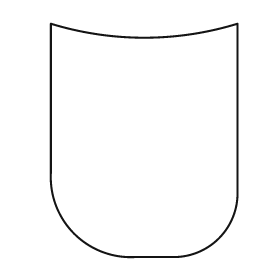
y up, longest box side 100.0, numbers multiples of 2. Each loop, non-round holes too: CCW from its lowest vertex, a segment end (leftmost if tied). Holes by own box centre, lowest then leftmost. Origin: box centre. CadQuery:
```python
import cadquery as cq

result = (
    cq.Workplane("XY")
    .moveTo(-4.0, -50.0)
    .lineTo(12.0, -50.0)
    .threePointArc((32.0, -42.0), (40.0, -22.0))
    .lineTo(40.0, 50.0)
    .threePointArc((0.0, 44.0), (-40.0, 50.0))
    .lineTo(-40.0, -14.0)
    .threePointArc((-30.0, -40.0), (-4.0, -50.0))
    .close()
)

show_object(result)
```